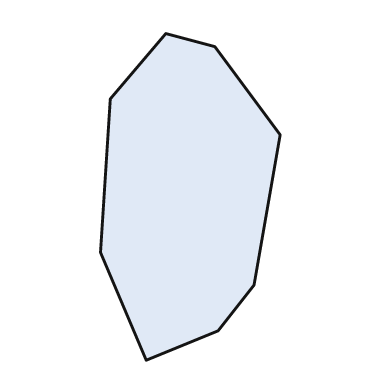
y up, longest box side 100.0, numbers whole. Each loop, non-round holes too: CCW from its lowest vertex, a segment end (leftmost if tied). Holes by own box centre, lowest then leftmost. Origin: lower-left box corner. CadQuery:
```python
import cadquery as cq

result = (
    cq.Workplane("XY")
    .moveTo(14.0, 0.0)
    .lineTo(36.0, 9.0)
    .lineTo(47.0, 23.0)
    .lineTo(55.0, 69.0)
    .lineTo(35.0, 96.0)
    .lineTo(20.0, 100.0)
    .lineTo(3.0, 80.0)
    .lineTo(0.0, 33.0)
    .close()
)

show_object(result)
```